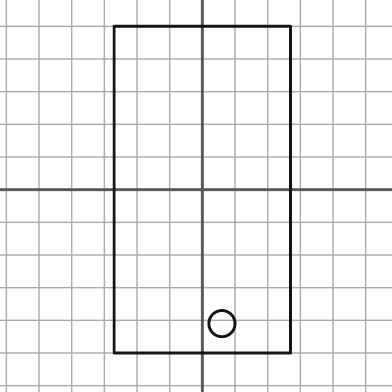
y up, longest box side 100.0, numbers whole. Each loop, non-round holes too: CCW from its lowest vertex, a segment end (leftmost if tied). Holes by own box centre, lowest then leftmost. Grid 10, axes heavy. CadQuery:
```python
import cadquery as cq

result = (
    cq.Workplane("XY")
    .moveTo(-27.0, -50.0)
    .lineTo(27.0, -50.0)
    .lineTo(27.0, 50.0)
    .lineTo(-27.0, 50.0)
    .close()
    .moveTo(6.0, -41.0)
    .circle(4.0)
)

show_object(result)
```